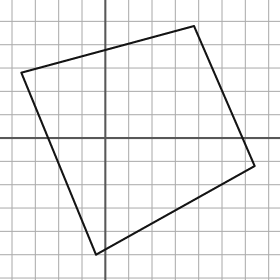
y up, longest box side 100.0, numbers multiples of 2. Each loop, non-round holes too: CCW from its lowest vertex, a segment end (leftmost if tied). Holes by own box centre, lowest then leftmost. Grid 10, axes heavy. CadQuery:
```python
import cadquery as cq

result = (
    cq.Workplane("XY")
    .moveTo(-4.0, -50.0)
    .lineTo(64.0, -12.0)
    .lineTo(38.0, 48.0)
    .lineTo(-36.0, 28.0)
    .close()
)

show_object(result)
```